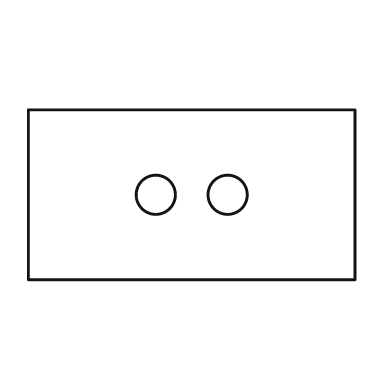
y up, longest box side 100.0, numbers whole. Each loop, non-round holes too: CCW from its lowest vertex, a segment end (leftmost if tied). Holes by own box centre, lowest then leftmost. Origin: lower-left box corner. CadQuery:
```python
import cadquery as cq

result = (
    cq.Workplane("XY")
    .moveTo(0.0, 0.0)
    .lineTo(100.0, 0.0)
    .lineTo(100.0, 52.0)
    .lineTo(0.0, 52.0)
    .close()
    .moveTo(39.0, 26.0)
    .circle(6.0)
    .moveTo(61.0, 26.0)
    .circle(6.0)
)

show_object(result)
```